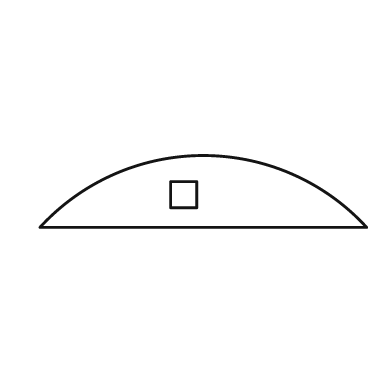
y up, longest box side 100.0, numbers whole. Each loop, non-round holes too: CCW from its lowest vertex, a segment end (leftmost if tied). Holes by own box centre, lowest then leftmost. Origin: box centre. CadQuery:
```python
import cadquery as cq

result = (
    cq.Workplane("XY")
    .moveTo(-50.0, -11.0)
    .lineTo(50.0, -11.0)
    .threePointArc((0.0, 11.0), (-50.0, -11.0))
    .close()
    .moveTo(-10.0, -5.0)
    .lineTo(-2.0, -5.0)
    .lineTo(-2.0, 3.0)
    .lineTo(-10.0, 3.0)
    .close()
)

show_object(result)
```